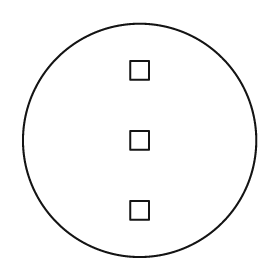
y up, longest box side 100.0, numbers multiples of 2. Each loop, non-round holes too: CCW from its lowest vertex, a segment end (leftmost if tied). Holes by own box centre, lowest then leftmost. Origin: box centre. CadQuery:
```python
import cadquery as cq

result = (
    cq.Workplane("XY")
    .moveTo(0.0, 0.0)
    .circle(50.0)
    .moveTo(-4.0, -34.0)
    .lineTo(4.0, -34.0)
    .lineTo(4.0, -26.0)
    .lineTo(-4.0, -26.0)
    .close()
    .moveTo(-4.0, -4.0)
    .lineTo(4.0, -4.0)
    .lineTo(4.0, 4.0)
    .lineTo(-4.0, 4.0)
    .close()
    .moveTo(-4.0, 26.0)
    .lineTo(4.0, 26.0)
    .lineTo(4.0, 34.0)
    .lineTo(-4.0, 34.0)
    .close()
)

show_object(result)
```